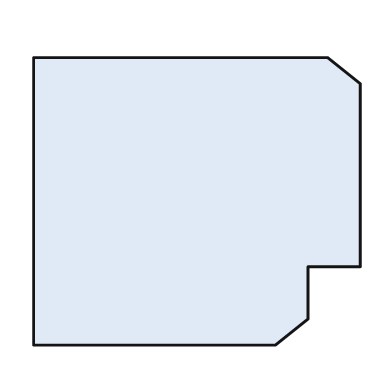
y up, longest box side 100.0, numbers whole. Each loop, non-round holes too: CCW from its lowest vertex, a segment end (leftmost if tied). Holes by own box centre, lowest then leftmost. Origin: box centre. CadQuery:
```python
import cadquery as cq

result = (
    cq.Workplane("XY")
    .moveTo(-50.0, -44.0)
    .lineTo(24.0, -44.0)
    .lineTo(34.0, -36.0)
    .lineTo(34.0, -20.0)
    .lineTo(50.0, -20.0)
    .lineTo(50.0, 36.0)
    .lineTo(40.0, 44.0)
    .lineTo(-50.0, 44.0)
    .close()
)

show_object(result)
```